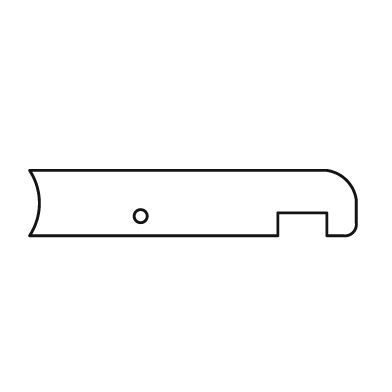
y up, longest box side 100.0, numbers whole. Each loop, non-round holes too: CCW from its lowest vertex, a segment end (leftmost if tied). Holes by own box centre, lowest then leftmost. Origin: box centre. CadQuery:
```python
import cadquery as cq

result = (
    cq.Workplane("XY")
    .moveTo(-50.0, -10.0)
    .lineTo(26.0, -10.0)
    .lineTo(26.0, -3.0)
    .lineTo(41.0, -3.0)
    .lineTo(41.0, -10.0)
    .lineTo(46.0, -10.0)
    .threePointArc((49.0, -9.0), (50.0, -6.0))
    .lineTo(50.0, 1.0)
    .threePointArc((47.0, 7.0), (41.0, 10.0))
    .lineTo(-50.0, 10.0)
    .threePointArc((-47.0, 0.0), (-50.0, -10.0))
    .close()
    .moveTo(-16.0, -4.0)
    .circle(2.0)
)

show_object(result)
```